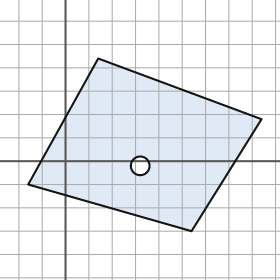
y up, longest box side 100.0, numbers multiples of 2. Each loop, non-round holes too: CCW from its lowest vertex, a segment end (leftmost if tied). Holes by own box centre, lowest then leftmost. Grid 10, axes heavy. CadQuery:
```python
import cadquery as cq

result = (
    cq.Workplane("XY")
    .moveTo(54.0, -30.0)
    .lineTo(84.0, 18.0)
    .lineTo(14.0, 44.0)
    .lineTo(-16.0, -10.0)
    .close()
    .moveTo(32.0, -2.0)
    .circle(4.0)
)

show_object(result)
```